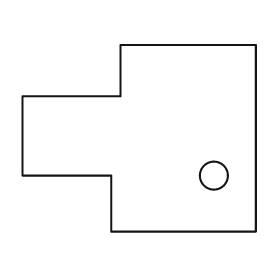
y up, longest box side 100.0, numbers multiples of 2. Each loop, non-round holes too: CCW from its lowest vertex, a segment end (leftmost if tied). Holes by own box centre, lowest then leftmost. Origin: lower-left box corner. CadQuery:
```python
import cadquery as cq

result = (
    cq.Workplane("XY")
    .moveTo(38.0, 0.0)
    .lineTo(100.0, 0.0)
    .lineTo(100.0, 80.0)
    .lineTo(42.0, 80.0)
    .lineTo(42.0, 58.0)
    .lineTo(0.0, 58.0)
    .lineTo(0.0, 24.0)
    .lineTo(38.0, 24.0)
    .close()
    .moveTo(82.0, 24.0)
    .circle(6.0)
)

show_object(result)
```